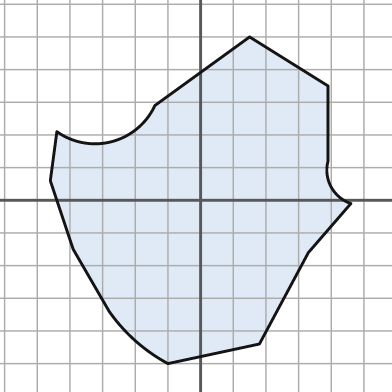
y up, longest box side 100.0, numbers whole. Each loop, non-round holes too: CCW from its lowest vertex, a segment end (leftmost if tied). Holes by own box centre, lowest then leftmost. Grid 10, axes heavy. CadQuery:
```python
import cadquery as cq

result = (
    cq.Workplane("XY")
    .moveTo(-10.0, -50.0)
    .lineTo(18.0, -44.0)
    .lineTo(33.0, -16.0)
    .lineTo(46.0, -1.0)
    .threePointArc((40.0, 4.0), (39.0, 12.0))
    .lineTo(39.0, 35.0)
    .lineTo(15.0, 50.0)
    .lineTo(-14.0, 29.0)
    .threePointArc((-27.0, 18.0), (-44.0, 21.0))
    .lineTo(-46.0, 6.0)
    .lineTo(-39.0, -15.0)
    .lineTo(-28.0, -34.0)
    .threePointArc((-20.0, -43.0), (-10.0, -50.0))
    .close()
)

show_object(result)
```